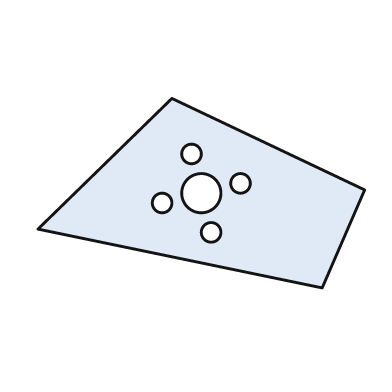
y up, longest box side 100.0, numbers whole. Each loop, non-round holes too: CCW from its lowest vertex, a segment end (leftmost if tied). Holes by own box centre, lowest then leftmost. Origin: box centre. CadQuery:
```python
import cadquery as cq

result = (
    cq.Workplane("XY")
    .moveTo(37.0, -29.0)
    .lineTo(50.0, 1.0)
    .lineTo(-9.0, 29.0)
    .lineTo(-50.0, -11.0)
    .close()
    .moveTo(3.0, -12.0)
    .circle(3.0)
    .moveTo(-12.0, -3.0)
    .circle(3.0)
    .moveTo(0.0, 0.0)
    .circle(6.0)
    .moveTo(12.0, 3.0)
    .circle(3.0)
    .moveTo(-3.0, 12.0)
    .circle(3.0)
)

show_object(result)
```